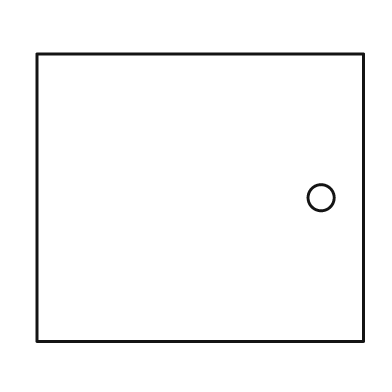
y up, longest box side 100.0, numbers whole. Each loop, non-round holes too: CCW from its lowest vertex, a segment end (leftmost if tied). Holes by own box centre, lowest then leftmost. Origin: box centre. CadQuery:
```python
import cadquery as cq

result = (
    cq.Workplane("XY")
    .moveTo(-50.0, -44.0)
    .lineTo(50.0, -44.0)
    .lineTo(50.0, 44.0)
    .lineTo(-50.0, 44.0)
    .close()
    .moveTo(37.0, 0.0)
    .circle(4.0)
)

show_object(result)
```